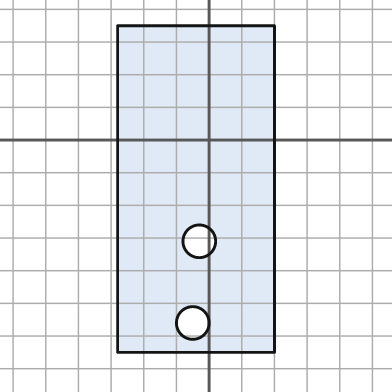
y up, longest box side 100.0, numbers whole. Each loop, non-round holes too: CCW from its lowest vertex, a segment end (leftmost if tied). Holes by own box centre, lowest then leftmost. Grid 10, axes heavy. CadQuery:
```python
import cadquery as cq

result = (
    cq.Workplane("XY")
    .moveTo(-28.0, -65.0)
    .lineTo(20.0, -65.0)
    .lineTo(20.0, 35.0)
    .lineTo(-28.0, 35.0)
    .close()
    .moveTo(-5.0, -56.0)
    .circle(5.0)
    .moveTo(-3.0, -31.0)
    .circle(5.0)
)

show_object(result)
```